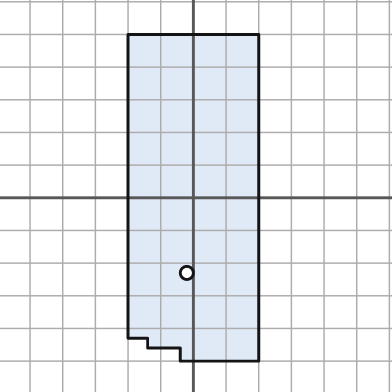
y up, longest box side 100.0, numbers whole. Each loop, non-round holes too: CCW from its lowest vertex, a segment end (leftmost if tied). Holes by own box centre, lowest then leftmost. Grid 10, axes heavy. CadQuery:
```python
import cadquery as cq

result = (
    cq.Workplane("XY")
    .moveTo(-4.0, -50.0)
    .lineTo(20.0, -50.0)
    .lineTo(20.0, 50.0)
    .lineTo(-20.0, 50.0)
    .lineTo(-20.0, -43.0)
    .lineTo(-14.0, -43.0)
    .lineTo(-14.0, -46.0)
    .lineTo(-4.0, -46.0)
    .close()
    .moveTo(-2.0, -23.0)
    .circle(2.0)
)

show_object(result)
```